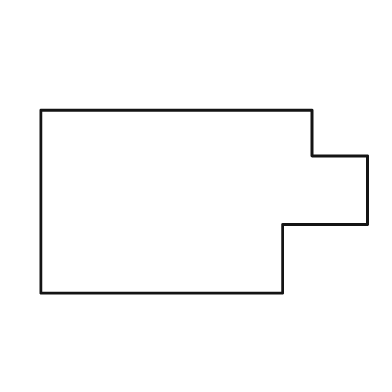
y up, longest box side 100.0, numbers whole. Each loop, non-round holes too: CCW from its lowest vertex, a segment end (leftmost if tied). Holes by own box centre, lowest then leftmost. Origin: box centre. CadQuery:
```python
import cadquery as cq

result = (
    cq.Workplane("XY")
    .moveTo(-50.0, -28.0)
    .lineTo(24.0, -28.0)
    .lineTo(24.0, -7.0)
    .lineTo(50.0, -7.0)
    .lineTo(50.0, 14.0)
    .lineTo(33.0, 14.0)
    .lineTo(33.0, 28.0)
    .lineTo(-50.0, 28.0)
    .close()
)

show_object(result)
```